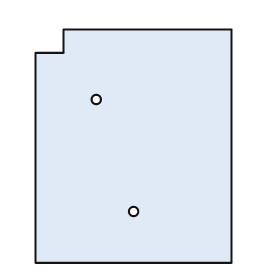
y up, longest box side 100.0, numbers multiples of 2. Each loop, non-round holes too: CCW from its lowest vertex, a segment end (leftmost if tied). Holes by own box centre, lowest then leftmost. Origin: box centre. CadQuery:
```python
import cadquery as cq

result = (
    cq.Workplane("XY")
    .moveTo(-42.0, -50.0)
    .lineTo(42.0, -50.0)
    .lineTo(42.0, 50.0)
    .lineTo(-30.0, 50.0)
    .lineTo(-30.0, 40.0)
    .lineTo(-42.0, 40.0)
    .close()
    .moveTo(0.0, -28.0)
    .circle(2.0)
    .moveTo(-16.0, 20.0)
    .circle(2.0)
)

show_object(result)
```